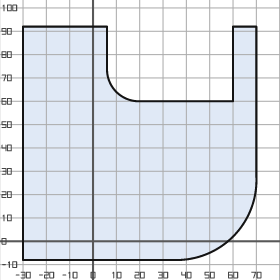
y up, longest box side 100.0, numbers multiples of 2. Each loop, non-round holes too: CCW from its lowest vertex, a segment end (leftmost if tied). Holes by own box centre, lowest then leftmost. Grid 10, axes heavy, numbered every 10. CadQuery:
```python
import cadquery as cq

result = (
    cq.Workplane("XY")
    .moveTo(-30.0, -8.0)
    .lineTo(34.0, -8.0)
    .threePointArc((60.0, 2.0), (70.0, 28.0))
    .lineTo(70.0, 92.0)
    .lineTo(60.0, 92.0)
    .lineTo(60.0, 60.0)
    .lineTo(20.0, 60.0)
    .threePointArc((10.0, 64.0), (6.0, 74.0))
    .lineTo(6.0, 92.0)
    .lineTo(-30.0, 92.0)
    .close()
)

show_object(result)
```